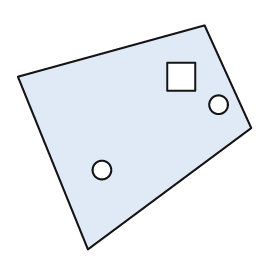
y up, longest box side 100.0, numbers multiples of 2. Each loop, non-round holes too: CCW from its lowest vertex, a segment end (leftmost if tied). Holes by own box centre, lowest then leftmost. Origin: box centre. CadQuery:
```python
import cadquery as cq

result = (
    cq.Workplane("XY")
    .moveTo(-20.0, -48.0)
    .lineTo(50.0, 4.0)
    .lineTo(30.0, 48.0)
    .lineTo(-50.0, 26.0)
    .close()
    .moveTo(-14.0, -14.0)
    .circle(4.0)
    .moveTo(36.0, 14.0)
    .circle(4.0)
    .moveTo(14.0, 20.0)
    .lineTo(26.0, 20.0)
    .lineTo(26.0, 32.0)
    .lineTo(14.0, 32.0)
    .close()
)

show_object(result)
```